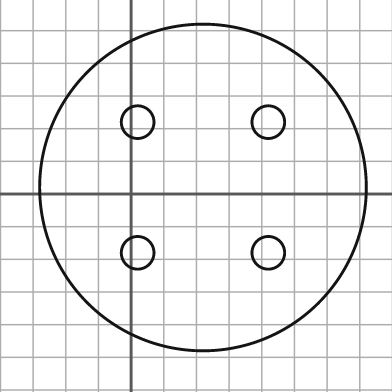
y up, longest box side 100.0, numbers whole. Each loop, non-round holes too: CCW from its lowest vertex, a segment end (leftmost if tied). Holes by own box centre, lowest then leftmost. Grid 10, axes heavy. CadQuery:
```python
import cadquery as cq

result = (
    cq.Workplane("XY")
    .moveTo(22.0, 2.0)
    .circle(50.0)
    .moveTo(2.0, -18.0)
    .circle(5.0)
    .moveTo(42.0, -18.0)
    .circle(5.0)
    .moveTo(2.0, 22.0)
    .circle(5.0)
    .moveTo(42.0, 22.0)
    .circle(5.0)
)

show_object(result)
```